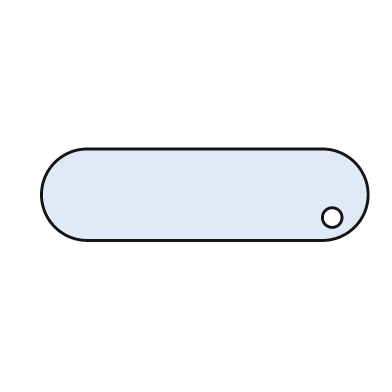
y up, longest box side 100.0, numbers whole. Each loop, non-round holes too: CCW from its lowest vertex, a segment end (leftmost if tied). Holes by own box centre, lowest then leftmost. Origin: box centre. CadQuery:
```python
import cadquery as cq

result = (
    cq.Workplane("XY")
    .moveTo(-36.0, -14.0)
    .lineTo(36.0, -14.0)
    .threePointArc((50.0, 0.0), (36.0, 14.0))
    .lineTo(-36.0, 14.0)
    .threePointArc((-50.0, 0.0), (-36.0, -14.0))
    .close()
    .moveTo(39.0, -7.0)
    .circle(3.0)
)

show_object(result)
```